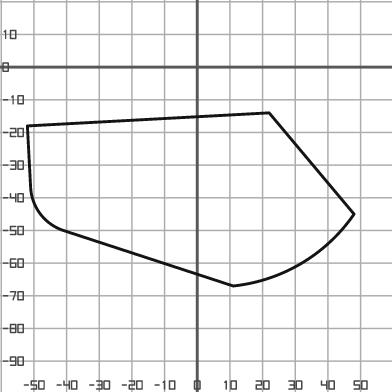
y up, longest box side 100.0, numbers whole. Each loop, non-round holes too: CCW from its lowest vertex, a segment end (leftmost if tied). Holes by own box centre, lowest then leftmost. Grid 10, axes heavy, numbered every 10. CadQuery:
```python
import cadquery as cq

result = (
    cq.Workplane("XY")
    .moveTo(11.0, -67.0)
    .threePointArc((32.0, -60.0), (48.0, -45.0))
    .lineTo(22.0, -14.0)
    .lineTo(-52.0, -18.0)
    .lineTo(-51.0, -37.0)
    .threePointArc((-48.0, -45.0), (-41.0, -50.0))
    .close()
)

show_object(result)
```